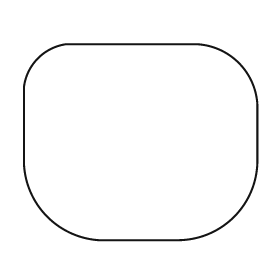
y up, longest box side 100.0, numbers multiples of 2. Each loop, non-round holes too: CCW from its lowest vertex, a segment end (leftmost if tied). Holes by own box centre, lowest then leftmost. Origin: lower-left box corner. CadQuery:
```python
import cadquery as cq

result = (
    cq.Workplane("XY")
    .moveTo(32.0, 0.0)
    .lineTo(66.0, 0.0)
    .threePointArc((90.0, 10.0), (100.0, 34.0))
    .lineTo(100.0, 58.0)
    .threePointArc((92.0, 76.0), (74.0, 84.0))
    .lineTo(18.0, 84.0)
    .threePointArc((6.0, 78.0), (0.0, 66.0))
    .lineTo(0.0, 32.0)
    .threePointArc((10.0, 10.0), (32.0, 0.0))
    .close()
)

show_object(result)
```